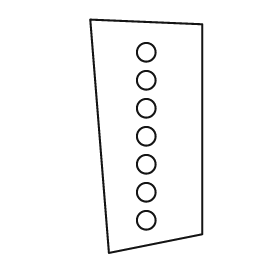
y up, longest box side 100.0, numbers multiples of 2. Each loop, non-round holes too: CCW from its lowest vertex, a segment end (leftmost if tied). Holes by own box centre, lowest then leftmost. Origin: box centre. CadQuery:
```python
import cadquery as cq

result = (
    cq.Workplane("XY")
    .moveTo(-16.0, -50.0)
    .lineTo(24.0, -42.0)
    .lineTo(24.0, 48.0)
    .lineTo(-24.0, 50.0)
    .close()
    .moveTo(0.0, -36.0)
    .circle(4.0)
    .moveTo(0.0, -24.0)
    .circle(4.0)
    .moveTo(0.0, -12.0)
    .circle(4.0)
    .moveTo(0.0, 0.0)
    .circle(4.0)
    .moveTo(0.0, 12.0)
    .circle(4.0)
    .moveTo(0.0, 24.0)
    .circle(4.0)
    .moveTo(0.0, 36.0)
    .circle(4.0)
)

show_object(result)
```